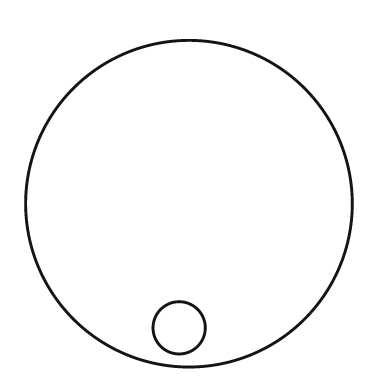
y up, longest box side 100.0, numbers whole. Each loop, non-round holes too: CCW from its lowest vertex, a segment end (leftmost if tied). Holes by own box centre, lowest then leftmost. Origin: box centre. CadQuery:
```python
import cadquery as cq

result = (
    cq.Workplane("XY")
    .moveTo(0.0, 0.0)
    .circle(50.0)
    .moveTo(-3.0, -38.0)
    .circle(8.0)
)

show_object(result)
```